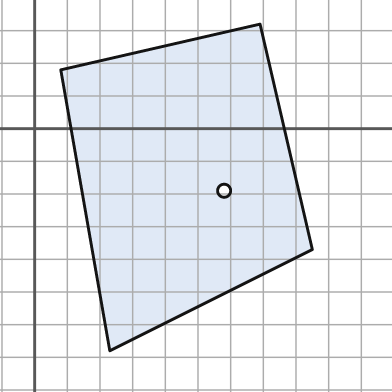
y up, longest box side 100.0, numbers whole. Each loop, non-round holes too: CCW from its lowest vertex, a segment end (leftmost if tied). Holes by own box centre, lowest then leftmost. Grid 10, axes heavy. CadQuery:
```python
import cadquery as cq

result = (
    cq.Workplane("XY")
    .moveTo(23.0, -68.0)
    .lineTo(85.0, -37.0)
    .lineTo(69.0, 32.0)
    .lineTo(8.0, 18.0)
    .close()
    .moveTo(58.0, -19.0)
    .circle(2.0)
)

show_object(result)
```